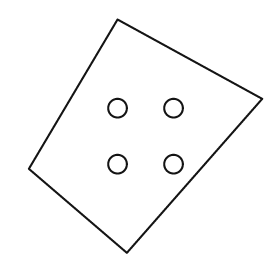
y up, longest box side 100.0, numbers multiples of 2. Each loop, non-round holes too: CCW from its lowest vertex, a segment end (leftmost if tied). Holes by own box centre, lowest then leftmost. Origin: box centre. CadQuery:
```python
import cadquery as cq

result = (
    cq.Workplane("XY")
    .moveTo(-8.0, -50.0)
    .lineTo(50.0, 16.0)
    .lineTo(-12.0, 50.0)
    .lineTo(-50.0, -14.0)
    .close()
    .moveTo(-12.0, -12.0)
    .circle(4.0)
    .moveTo(12.0, -12.0)
    .circle(4.0)
    .moveTo(-12.0, 12.0)
    .circle(4.0)
    .moveTo(12.0, 12.0)
    .circle(4.0)
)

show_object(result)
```